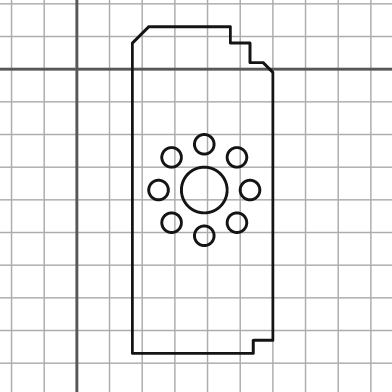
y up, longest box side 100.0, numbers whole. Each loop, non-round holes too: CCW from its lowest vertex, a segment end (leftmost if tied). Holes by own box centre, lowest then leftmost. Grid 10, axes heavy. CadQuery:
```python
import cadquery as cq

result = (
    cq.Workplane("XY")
    .moveTo(17.0, -87.0)
    .lineTo(54.0, -87.0)
    .lineTo(54.0, -83.0)
    .lineTo(60.0, -83.0)
    .lineTo(60.0, -1.0)
    .lineTo(57.0, 2.0)
    .lineTo(53.0, 2.0)
    .lineTo(53.0, 8.0)
    .lineTo(47.0, 8.0)
    .lineTo(47.0, 13.0)
    .lineTo(22.0, 13.0)
    .lineTo(17.0, 8.0)
    .close()
    .moveTo(39.0, -51.0)
    .circle(3.0)
    .moveTo(29.0, -47.0)
    .circle(3.0)
    .moveTo(49.0, -47.0)
    .circle(3.0)
    .moveTo(25.0, -37.0)
    .circle(3.0)
    .moveTo(39.0, -37.0)
    .circle(7.0)
    .moveTo(53.0, -37.0)
    .circle(3.0)
    .moveTo(29.0, -27.0)
    .circle(3.0)
    .moveTo(49.0, -27.0)
    .circle(3.0)
    .moveTo(39.0, -23.0)
    .circle(3.0)
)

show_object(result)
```